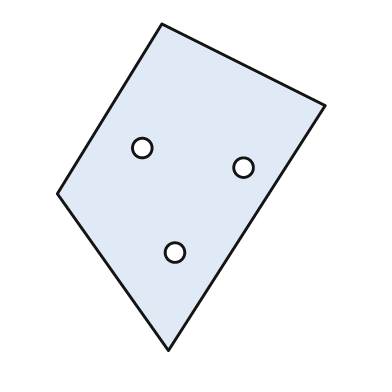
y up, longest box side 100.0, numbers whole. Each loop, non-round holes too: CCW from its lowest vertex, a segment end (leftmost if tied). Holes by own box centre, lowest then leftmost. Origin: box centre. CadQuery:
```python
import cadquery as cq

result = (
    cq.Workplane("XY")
    .moveTo(-7.0, -50.0)
    .lineTo(41.0, 25.0)
    .lineTo(-9.0, 50.0)
    .lineTo(-41.0, -2.0)
    .close()
    .moveTo(-5.0, -20.0)
    .circle(3.0)
    .moveTo(16.0, 6.0)
    .circle(3.0)
    .moveTo(-15.0, 12.0)
    .circle(3.0)
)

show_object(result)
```